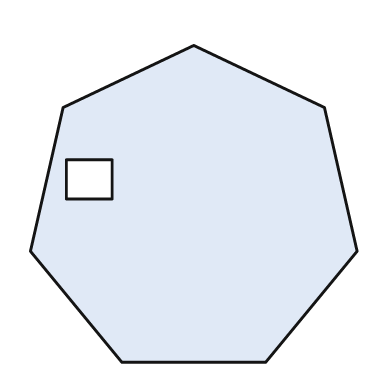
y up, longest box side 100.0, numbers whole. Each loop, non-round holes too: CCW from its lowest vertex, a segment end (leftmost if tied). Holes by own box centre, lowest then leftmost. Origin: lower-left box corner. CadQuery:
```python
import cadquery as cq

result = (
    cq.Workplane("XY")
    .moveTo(28.0, 0.0)
    .lineTo(72.0, 0.0)
    .lineTo(100.0, 34.0)
    .lineTo(90.0, 78.0)
    .lineTo(50.0, 97.0)
    .lineTo(10.0, 78.0)
    .lineTo(0.0, 34.0)
    .close()
    .moveTo(11.0, 50.0)
    .lineTo(25.0, 50.0)
    .lineTo(25.0, 62.0)
    .lineTo(11.0, 62.0)
    .close()
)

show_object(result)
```